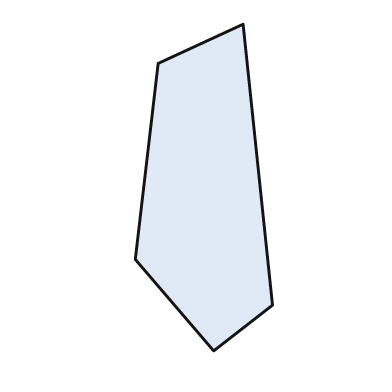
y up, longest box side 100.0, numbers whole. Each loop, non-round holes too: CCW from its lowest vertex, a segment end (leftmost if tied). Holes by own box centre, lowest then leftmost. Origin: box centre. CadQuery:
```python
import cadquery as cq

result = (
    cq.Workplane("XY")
    .moveTo(3.0, -50.0)
    .lineTo(21.0, -36.0)
    .lineTo(12.0, 50.0)
    .lineTo(-14.0, 38.0)
    .lineTo(-21.0, -22.0)
    .close()
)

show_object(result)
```